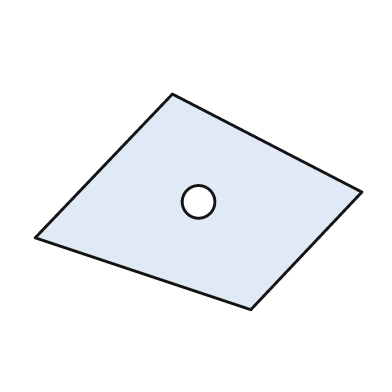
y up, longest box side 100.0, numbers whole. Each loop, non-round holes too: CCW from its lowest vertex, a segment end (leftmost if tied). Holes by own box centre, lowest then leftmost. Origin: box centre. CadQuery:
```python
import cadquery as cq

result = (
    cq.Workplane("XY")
    .moveTo(16.0, -33.0)
    .lineTo(50.0, 3.0)
    .lineTo(-8.0, 33.0)
    .lineTo(-50.0, -11.0)
    .close()
    .moveTo(0.0, 0.0)
    .circle(5.0)
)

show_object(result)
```